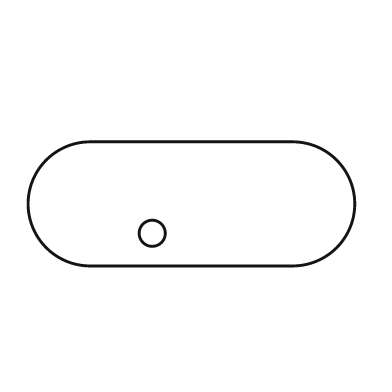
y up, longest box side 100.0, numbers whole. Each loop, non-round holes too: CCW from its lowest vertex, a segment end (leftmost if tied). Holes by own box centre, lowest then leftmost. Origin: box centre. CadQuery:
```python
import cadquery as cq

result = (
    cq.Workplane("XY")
    .moveTo(-31.0, -19.0)
    .lineTo(31.0, -19.0)
    .threePointArc((50.0, 0.0), (31.0, 19.0))
    .lineTo(-31.0, 19.0)
    .threePointArc((-50.0, 0.0), (-31.0, -19.0))
    .close()
    .moveTo(-12.0, -9.0)
    .circle(4.0)
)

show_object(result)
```